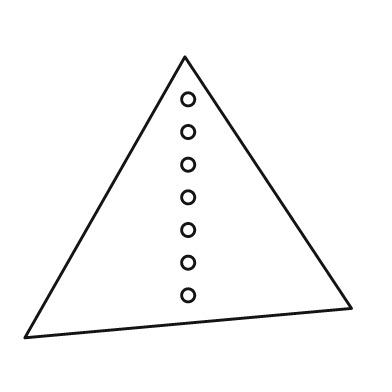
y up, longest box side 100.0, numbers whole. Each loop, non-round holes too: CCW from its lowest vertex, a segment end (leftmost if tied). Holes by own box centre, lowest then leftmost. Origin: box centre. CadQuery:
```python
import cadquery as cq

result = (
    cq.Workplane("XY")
    .moveTo(-50.0, -43.0)
    .lineTo(50.0, -34.0)
    .lineTo(-1.0, 43.0)
    .close()
    .moveTo(0.0, -30.0)
    .circle(2.0)
    .moveTo(0.0, -20.0)
    .circle(2.0)
    .moveTo(0.0, -10.0)
    .circle(2.0)
    .moveTo(0.0, 0.0)
    .circle(2.0)
    .moveTo(0.0, 10.0)
    .circle(2.0)
    .moveTo(0.0, 20.0)
    .circle(2.0)
    .moveTo(0.0, 30.0)
    .circle(2.0)
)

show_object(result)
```